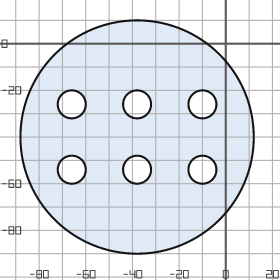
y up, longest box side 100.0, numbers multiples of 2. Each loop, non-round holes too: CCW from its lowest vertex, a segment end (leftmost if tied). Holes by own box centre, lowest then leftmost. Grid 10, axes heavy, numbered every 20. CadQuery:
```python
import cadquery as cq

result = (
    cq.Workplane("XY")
    .moveTo(-38.0, -40.0)
    .circle(50.0)
    .moveTo(-66.0, -54.0)
    .circle(6.0)
    .moveTo(-38.0, -54.0)
    .circle(6.0)
    .moveTo(-10.0, -54.0)
    .circle(6.0)
    .moveTo(-66.0, -26.0)
    .circle(6.0)
    .moveTo(-38.0, -26.0)
    .circle(6.0)
    .moveTo(-10.0, -26.0)
    .circle(6.0)
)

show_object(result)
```